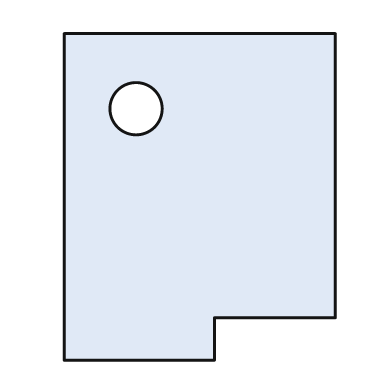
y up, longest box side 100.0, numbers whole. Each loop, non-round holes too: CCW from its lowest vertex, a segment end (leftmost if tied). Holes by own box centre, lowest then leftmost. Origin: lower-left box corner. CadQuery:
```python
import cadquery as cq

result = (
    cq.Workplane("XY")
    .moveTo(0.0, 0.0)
    .lineTo(46.0, 0.0)
    .lineTo(46.0, 13.0)
    .lineTo(83.0, 13.0)
    .lineTo(83.0, 100.0)
    .lineTo(0.0, 100.0)
    .close()
    .moveTo(22.0, 77.0)
    .circle(8.0)
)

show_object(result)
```